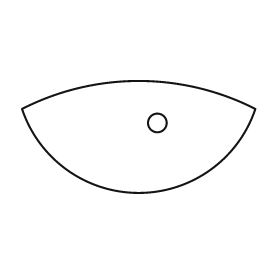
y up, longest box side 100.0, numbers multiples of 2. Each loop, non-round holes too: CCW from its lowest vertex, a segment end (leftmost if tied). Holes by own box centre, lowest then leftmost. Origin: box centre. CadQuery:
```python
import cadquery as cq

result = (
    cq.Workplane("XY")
    .moveTo(-50.0, 12.0)
    .threePointArc((0.0, -24.0), (50.0, 12.0))
    .threePointArc((0.0, 24.0), (-50.0, 12.0))
    .close()
    .moveTo(8.0, 6.0)
    .circle(4.0)
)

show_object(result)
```